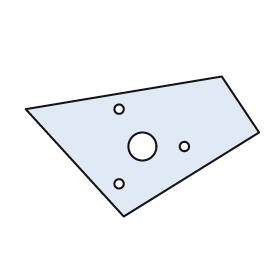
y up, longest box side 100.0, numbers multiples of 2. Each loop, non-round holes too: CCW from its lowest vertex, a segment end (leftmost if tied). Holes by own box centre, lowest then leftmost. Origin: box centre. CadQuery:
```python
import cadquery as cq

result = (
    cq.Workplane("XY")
    .moveTo(-8.0, -30.0)
    .lineTo(50.0, 6.0)
    .lineTo(34.0, 30.0)
    .lineTo(-50.0, 16.0)
    .close()
    .moveTo(-10.0, -16.0)
    .circle(2.0)
    .moveTo(0.0, 0.0)
    .circle(6.0)
    .moveTo(18.0, 0.0)
    .circle(2.0)
    .moveTo(-10.0, 16.0)
    .circle(2.0)
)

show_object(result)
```